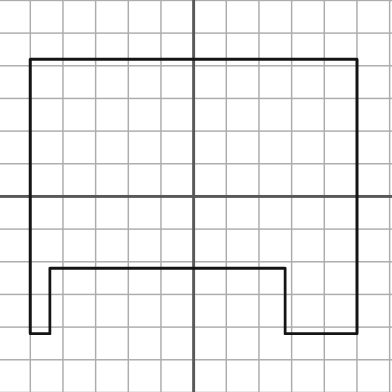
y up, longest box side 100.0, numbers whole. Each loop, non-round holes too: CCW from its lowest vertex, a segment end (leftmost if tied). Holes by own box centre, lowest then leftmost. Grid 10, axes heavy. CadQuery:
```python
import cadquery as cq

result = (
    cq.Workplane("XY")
    .moveTo(-50.0, -42.0)
    .lineTo(-44.0, -42.0)
    .lineTo(-44.0, -22.0)
    .lineTo(28.0, -22.0)
    .lineTo(28.0, -42.0)
    .lineTo(50.0, -42.0)
    .lineTo(50.0, 42.0)
    .lineTo(-50.0, 42.0)
    .close()
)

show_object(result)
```